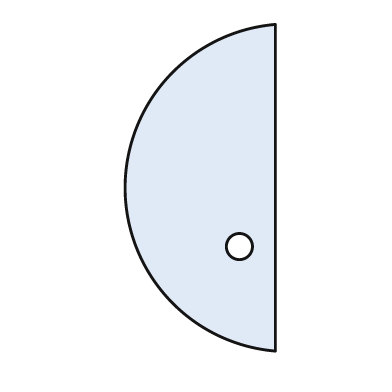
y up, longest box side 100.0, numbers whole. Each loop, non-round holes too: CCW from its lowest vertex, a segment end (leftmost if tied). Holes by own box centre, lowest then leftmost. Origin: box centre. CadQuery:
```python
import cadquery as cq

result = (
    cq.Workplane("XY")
    .moveTo(23.0, -50.0)
    .lineTo(23.0, 50.0)
    .threePointArc((-23.0, 0.0), (23.0, -50.0))
    .close()
    .moveTo(12.0, -18.0)
    .circle(4.0)
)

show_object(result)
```